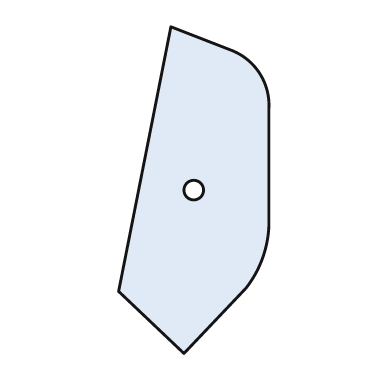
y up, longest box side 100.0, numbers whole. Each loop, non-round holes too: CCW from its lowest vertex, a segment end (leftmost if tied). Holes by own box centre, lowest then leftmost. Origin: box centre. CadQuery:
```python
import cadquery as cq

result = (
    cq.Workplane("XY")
    .moveTo(-3.0, -50.0)
    .lineTo(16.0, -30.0)
    .threePointArc((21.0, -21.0), (23.0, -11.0))
    .lineTo(23.0, 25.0)
    .threePointArc((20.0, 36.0), (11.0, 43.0))
    .lineTo(-7.0, 50.0)
    .lineTo(-23.0, -31.0)
    .close()
    .moveTo(0.0, 0.0)
    .circle(3.0)
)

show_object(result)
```